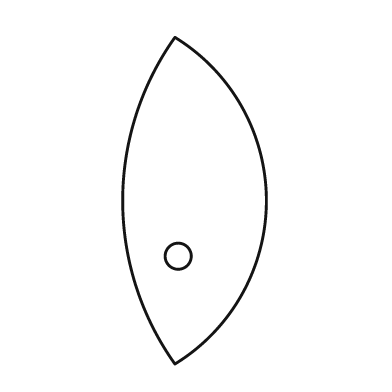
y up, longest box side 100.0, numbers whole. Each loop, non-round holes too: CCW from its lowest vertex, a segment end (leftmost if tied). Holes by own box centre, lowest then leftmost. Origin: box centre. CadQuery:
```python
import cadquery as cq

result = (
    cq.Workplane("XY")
    .moveTo(-6.0, -50.0)
    .threePointArc((22.0, 0.0), (-6.0, 50.0))
    .threePointArc((-22.0, 0.0), (-6.0, -50.0))
    .close()
    .moveTo(-5.0, -17.0)
    .circle(4.0)
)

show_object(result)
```